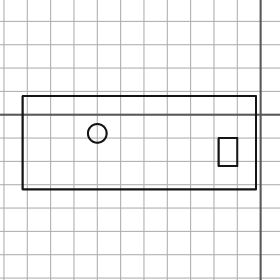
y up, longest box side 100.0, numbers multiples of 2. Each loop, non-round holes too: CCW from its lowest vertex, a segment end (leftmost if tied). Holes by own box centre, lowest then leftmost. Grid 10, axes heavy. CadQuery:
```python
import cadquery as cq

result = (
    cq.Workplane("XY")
    .moveTo(-102.0, -32.0)
    .lineTo(-2.0, -32.0)
    .lineTo(-2.0, 8.0)
    .lineTo(-102.0, 8.0)
    .close()
    .moveTo(-18.0, -22.0)
    .lineTo(-10.0, -22.0)
    .lineTo(-10.0, -10.0)
    .lineTo(-18.0, -10.0)
    .close()
    .moveTo(-70.0, -8.0)
    .circle(4.0)
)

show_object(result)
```